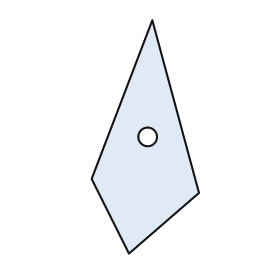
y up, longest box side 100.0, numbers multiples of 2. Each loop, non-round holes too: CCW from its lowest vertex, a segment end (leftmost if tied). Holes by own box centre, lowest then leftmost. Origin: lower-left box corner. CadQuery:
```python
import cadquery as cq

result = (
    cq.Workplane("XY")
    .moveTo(16.0, 0.0)
    .lineTo(46.0, 26.0)
    .lineTo(26.0, 100.0)
    .lineTo(0.0, 32.0)
    .close()
    .moveTo(24.0, 50.0)
    .circle(4.0)
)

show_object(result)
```